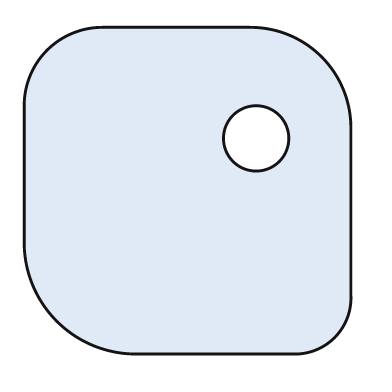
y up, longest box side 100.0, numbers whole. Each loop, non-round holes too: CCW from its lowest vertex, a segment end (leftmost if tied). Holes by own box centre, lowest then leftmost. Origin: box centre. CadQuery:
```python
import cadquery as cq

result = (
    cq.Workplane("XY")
    .moveTo(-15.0, -50.0)
    .lineTo(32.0, -50.0)
    .threePointArc((45.0, -45.0), (50.0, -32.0))
    .lineTo(50.0, 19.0)
    .threePointArc((41.0, 41.0), (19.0, 50.0))
    .lineTo(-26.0, 50.0)
    .threePointArc((-43.0, 43.0), (-50.0, 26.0))
    .lineTo(-50.0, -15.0)
    .threePointArc((-40.0, -40.0), (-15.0, -50.0))
    .close()
    .moveTo(21.0, 16.0)
    .circle(10.0)
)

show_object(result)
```